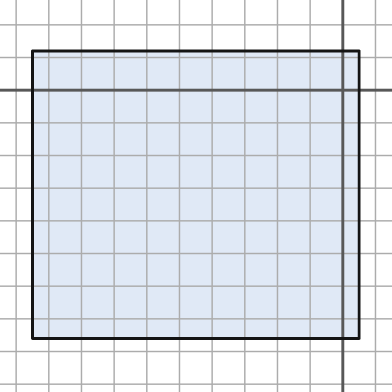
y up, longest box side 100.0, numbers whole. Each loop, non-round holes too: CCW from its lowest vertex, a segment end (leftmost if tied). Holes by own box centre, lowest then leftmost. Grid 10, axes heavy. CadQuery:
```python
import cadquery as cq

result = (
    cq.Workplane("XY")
    .moveTo(-95.0, -76.0)
    .lineTo(5.0, -76.0)
    .lineTo(5.0, 12.0)
    .lineTo(-95.0, 12.0)
    .close()
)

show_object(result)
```